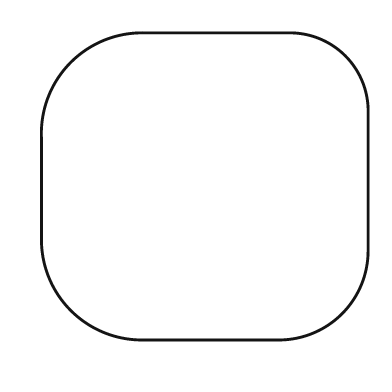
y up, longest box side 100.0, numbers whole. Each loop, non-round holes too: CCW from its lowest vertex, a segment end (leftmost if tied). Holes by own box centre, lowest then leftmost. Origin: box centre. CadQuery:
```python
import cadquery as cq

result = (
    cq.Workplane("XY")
    .moveTo(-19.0, -47.0)
    .lineTo(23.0, -47.0)
    .threePointArc((42.0, -39.0), (50.0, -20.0))
    .lineTo(50.0, 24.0)
    .threePointArc((43.0, 40.0), (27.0, 47.0))
    .lineTo(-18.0, 47.0)
    .threePointArc((-41.0, 38.0), (-50.0, 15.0))
    .lineTo(-50.0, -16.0)
    .threePointArc((-41.0, -38.0), (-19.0, -47.0))
    .close()
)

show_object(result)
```